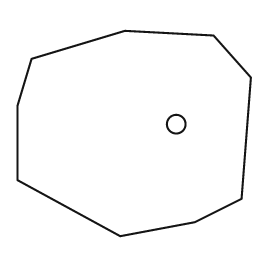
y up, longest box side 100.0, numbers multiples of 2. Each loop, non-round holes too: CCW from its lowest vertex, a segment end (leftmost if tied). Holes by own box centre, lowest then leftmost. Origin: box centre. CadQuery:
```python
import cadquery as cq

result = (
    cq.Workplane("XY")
    .moveTo(-6.0, -44.0)
    .lineTo(26.0, -38.0)
    .lineTo(46.0, -28.0)
    .lineTo(50.0, 24.0)
    .lineTo(34.0, 42.0)
    .lineTo(-4.0, 44.0)
    .lineTo(-44.0, 32.0)
    .lineTo(-50.0, 12.0)
    .lineTo(-50.0, -20.0)
    .close()
    .moveTo(18.0, 4.0)
    .circle(4.0)
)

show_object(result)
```